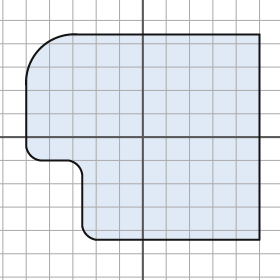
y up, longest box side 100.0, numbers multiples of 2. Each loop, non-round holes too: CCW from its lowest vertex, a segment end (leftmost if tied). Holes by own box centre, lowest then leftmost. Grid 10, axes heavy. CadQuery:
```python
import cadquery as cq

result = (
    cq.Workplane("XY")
    .moveTo(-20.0, -44.0)
    .lineTo(50.0, -44.0)
    .lineTo(50.0, 44.0)
    .lineTo(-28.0, 44.0)
    .threePointArc((-44.0, 38.0), (-50.0, 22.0))
    .lineTo(-50.0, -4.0)
    .threePointArc((-48.0, -8.0), (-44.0, -10.0))
    .lineTo(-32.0, -10.0)
    .threePointArc((-28.0, -12.0), (-26.0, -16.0))
    .lineTo(-26.0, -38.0)
    .threePointArc((-24.0, -42.0), (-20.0, -44.0))
    .close()
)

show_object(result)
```